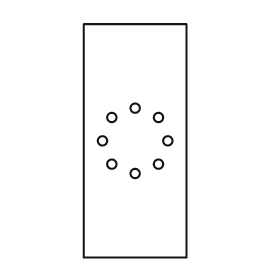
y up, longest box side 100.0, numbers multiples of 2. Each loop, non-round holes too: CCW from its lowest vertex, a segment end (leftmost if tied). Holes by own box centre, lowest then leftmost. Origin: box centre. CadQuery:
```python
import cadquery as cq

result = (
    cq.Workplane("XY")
    .moveTo(-22.0, -50.0)
    .lineTo(22.0, -50.0)
    .lineTo(22.0, 50.0)
    .lineTo(-22.0, 50.0)
    .close()
    .moveTo(0.0, -14.0)
    .circle(2.0)
    .moveTo(-10.0, -10.0)
    .circle(2.0)
    .moveTo(10.0, -10.0)
    .circle(2.0)
    .moveTo(-14.0, 0.0)
    .circle(2.0)
    .moveTo(14.0, 0.0)
    .circle(2.0)
    .moveTo(-10.0, 10.0)
    .circle(2.0)
    .moveTo(10.0, 10.0)
    .circle(2.0)
    .moveTo(0.0, 14.0)
    .circle(2.0)
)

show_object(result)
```